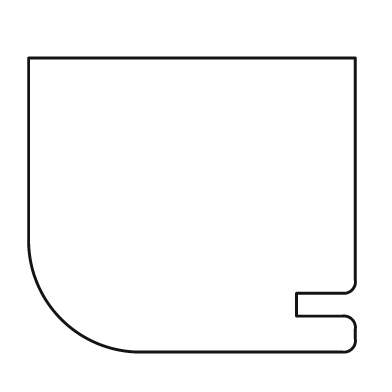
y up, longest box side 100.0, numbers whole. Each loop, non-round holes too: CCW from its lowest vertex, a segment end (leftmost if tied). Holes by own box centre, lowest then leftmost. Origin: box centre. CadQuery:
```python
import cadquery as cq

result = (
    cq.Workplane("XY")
    .moveTo(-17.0, -45.0)
    .lineTo(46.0, -45.0)
    .threePointArc((49.0, -44.0), (50.0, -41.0))
    .lineTo(50.0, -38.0)
    .threePointArc((49.0, -35.0), (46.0, -34.0))
    .lineTo(32.0, -34.0)
    .lineTo(32.0, -27.0)
    .lineTo(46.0, -27.0)
    .threePointArc((49.0, -26.0), (50.0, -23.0))
    .lineTo(50.0, 45.0)
    .lineTo(-50.0, 45.0)
    .lineTo(-50.0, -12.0)
    .threePointArc((-40.0, -35.0), (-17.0, -45.0))
    .close()
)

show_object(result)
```